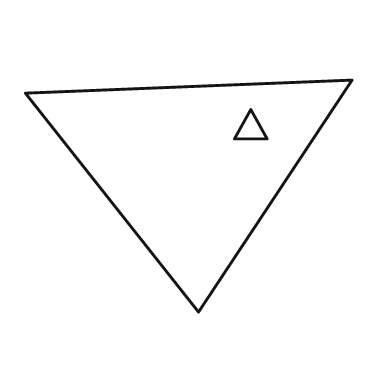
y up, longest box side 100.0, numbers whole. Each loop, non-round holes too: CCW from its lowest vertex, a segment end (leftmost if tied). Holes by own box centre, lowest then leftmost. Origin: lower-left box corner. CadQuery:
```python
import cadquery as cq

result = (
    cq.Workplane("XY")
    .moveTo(53.0, 0.0)
    .lineTo(100.0, 71.0)
    .lineTo(0.0, 67.0)
    .close()
    .moveTo(64.0, 53.0)
    .lineTo(74.0, 53.0)
    .lineTo(69.0, 62.0)
    .close()
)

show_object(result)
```